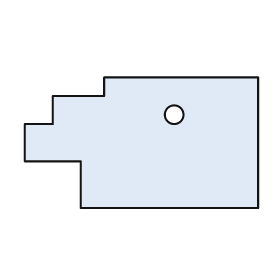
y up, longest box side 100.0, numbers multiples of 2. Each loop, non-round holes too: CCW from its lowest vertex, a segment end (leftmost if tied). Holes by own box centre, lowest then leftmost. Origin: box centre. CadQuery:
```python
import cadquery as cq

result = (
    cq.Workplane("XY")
    .moveTo(-26.0, -28.0)
    .lineTo(50.0, -28.0)
    .lineTo(50.0, 28.0)
    .lineTo(-16.0, 28.0)
    .lineTo(-16.0, 20.0)
    .lineTo(-38.0, 20.0)
    .lineTo(-38.0, 8.0)
    .lineTo(-50.0, 8.0)
    .lineTo(-50.0, -8.0)
    .lineTo(-26.0, -8.0)
    .close()
    .moveTo(14.0, 12.0)
    .circle(4.0)
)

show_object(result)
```